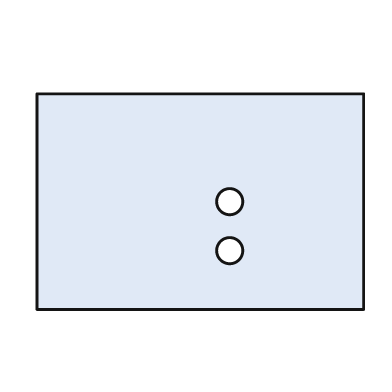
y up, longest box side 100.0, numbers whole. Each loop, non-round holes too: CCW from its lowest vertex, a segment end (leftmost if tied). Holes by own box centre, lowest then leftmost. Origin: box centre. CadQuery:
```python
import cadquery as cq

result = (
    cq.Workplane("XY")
    .moveTo(-50.0, -33.0)
    .lineTo(50.0, -33.0)
    .lineTo(50.0, 33.0)
    .lineTo(-50.0, 33.0)
    .close()
    .moveTo(9.0, -15.0)
    .circle(4.0)
    .moveTo(9.0, 0.0)
    .circle(4.0)
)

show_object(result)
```